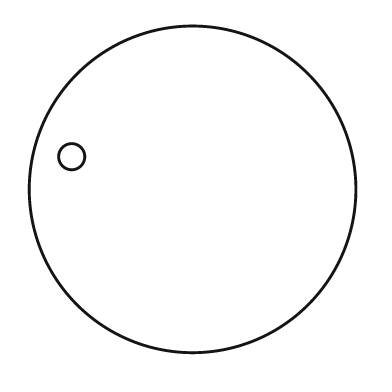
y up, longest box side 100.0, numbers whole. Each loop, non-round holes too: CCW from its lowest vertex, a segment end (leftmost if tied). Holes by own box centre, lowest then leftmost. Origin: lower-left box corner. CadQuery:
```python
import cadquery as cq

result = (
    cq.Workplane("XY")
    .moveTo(50.0, 50.0)
    .circle(50.0)
    .moveTo(13.0, 60.0)
    .circle(4.0)
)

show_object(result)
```